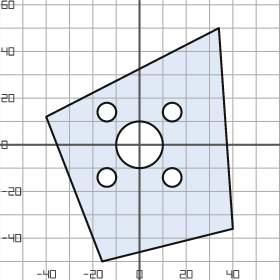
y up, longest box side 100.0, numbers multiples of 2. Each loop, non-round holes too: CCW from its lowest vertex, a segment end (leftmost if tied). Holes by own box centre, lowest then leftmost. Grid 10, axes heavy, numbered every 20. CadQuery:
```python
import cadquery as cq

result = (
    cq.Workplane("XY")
    .moveTo(-16.0, -50.0)
    .lineTo(40.0, -36.0)
    .lineTo(34.0, 50.0)
    .lineTo(-40.0, 12.0)
    .close()
    .moveTo(-14.0, -14.0)
    .circle(4.0)
    .moveTo(14.0, -14.0)
    .circle(4.0)
    .moveTo(0.0, 0.0)
    .circle(10.0)
    .moveTo(-14.0, 14.0)
    .circle(4.0)
    .moveTo(14.0, 14.0)
    .circle(4.0)
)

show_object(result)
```